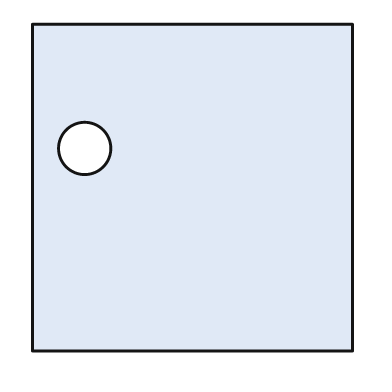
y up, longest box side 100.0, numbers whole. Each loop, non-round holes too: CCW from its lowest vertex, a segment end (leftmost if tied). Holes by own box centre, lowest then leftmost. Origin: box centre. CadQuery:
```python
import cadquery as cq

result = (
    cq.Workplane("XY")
    .moveTo(-49.0, -50.0)
    .lineTo(49.0, -50.0)
    .lineTo(49.0, 50.0)
    .lineTo(-49.0, 50.0)
    .close()
    .moveTo(-33.0, 12.0)
    .circle(8.0)
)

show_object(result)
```